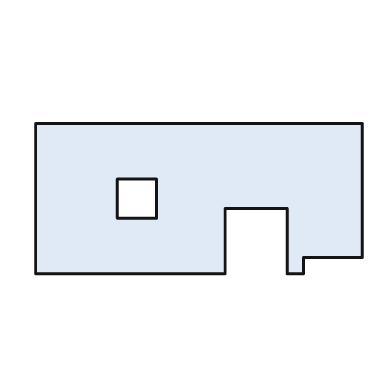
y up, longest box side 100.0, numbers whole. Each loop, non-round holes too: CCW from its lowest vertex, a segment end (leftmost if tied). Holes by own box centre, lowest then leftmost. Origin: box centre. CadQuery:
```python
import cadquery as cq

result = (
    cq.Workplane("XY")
    .moveTo(-50.0, -23.0)
    .lineTo(8.0, -23.0)
    .lineTo(8.0, -3.0)
    .lineTo(27.0, -3.0)
    .lineTo(27.0, -23.0)
    .lineTo(32.0, -23.0)
    .lineTo(32.0, -18.0)
    .lineTo(50.0, -18.0)
    .lineTo(50.0, 23.0)
    .lineTo(-50.0, 23.0)
    .close()
    .moveTo(-25.0, -6.0)
    .lineTo(-13.0, -6.0)
    .lineTo(-13.0, 6.0)
    .lineTo(-25.0, 6.0)
    .close()
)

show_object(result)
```